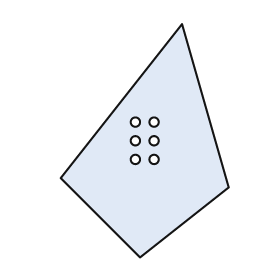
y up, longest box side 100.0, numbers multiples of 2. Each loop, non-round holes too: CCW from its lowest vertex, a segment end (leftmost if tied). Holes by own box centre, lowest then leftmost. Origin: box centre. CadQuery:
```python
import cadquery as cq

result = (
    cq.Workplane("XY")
    .moveTo(-2.0, -50.0)
    .lineTo(36.0, -20.0)
    .lineTo(16.0, 50.0)
    .lineTo(-36.0, -16.0)
    .close()
    .moveTo(-4.0, -8.0)
    .circle(2.0)
    .moveTo(4.0, -8.0)
    .circle(2.0)
    .moveTo(-4.0, 0.0)
    .circle(2.0)
    .moveTo(4.0, 0.0)
    .circle(2.0)
    .moveTo(-4.0, 8.0)
    .circle(2.0)
    .moveTo(4.0, 8.0)
    .circle(2.0)
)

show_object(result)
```